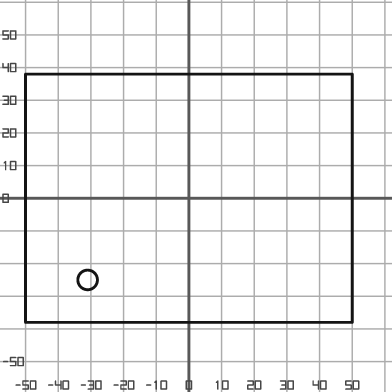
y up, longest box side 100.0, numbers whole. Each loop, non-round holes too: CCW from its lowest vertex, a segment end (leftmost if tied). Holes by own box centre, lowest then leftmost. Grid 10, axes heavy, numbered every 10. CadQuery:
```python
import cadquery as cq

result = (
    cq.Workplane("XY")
    .moveTo(-50.0, -38.0)
    .lineTo(50.0, -38.0)
    .lineTo(50.0, 38.0)
    .lineTo(-50.0, 38.0)
    .close()
    .moveTo(-31.0, -25.0)
    .circle(3.0)
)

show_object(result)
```